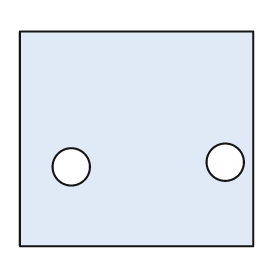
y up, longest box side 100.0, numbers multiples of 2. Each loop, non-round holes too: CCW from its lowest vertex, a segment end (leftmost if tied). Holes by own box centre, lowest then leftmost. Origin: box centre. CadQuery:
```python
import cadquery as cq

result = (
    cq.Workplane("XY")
    .moveTo(-50.0, -46.0)
    .lineTo(50.0, -46.0)
    .lineTo(50.0, 46.0)
    .lineTo(-50.0, 46.0)
    .close()
    .moveTo(-28.0, -12.0)
    .circle(8.0)
    .moveTo(38.0, -10.0)
    .circle(8.0)
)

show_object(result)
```